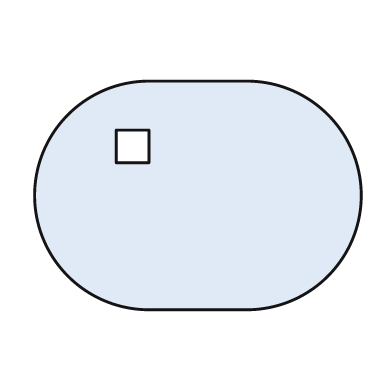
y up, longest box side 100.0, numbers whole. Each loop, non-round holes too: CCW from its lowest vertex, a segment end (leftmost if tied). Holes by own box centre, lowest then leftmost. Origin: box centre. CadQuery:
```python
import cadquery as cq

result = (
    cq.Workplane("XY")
    .moveTo(-15.0, -35.0)
    .lineTo(15.0, -35.0)
    .threePointArc((50.0, 0.0), (15.0, 35.0))
    .lineTo(-15.0, 35.0)
    .threePointArc((-50.0, 0.0), (-15.0, -35.0))
    .close()
    .moveTo(-25.0, 10.0)
    .lineTo(-15.0, 10.0)
    .lineTo(-15.0, 20.0)
    .lineTo(-25.0, 20.0)
    .close()
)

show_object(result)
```